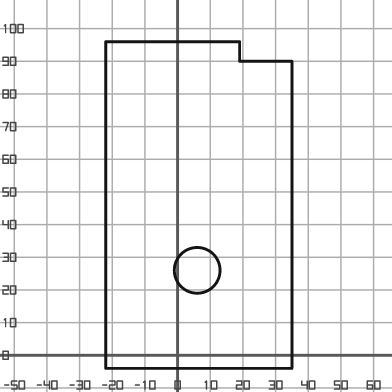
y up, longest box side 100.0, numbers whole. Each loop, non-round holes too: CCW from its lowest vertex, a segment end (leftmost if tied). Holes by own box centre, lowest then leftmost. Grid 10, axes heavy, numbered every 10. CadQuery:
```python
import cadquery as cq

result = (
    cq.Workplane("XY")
    .moveTo(-22.0, -4.0)
    .lineTo(35.0, -4.0)
    .lineTo(35.0, 90.0)
    .lineTo(19.0, 90.0)
    .lineTo(19.0, 96.0)
    .lineTo(-22.0, 96.0)
    .close()
    .moveTo(6.0, 26.0)
    .circle(7.0)
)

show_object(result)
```